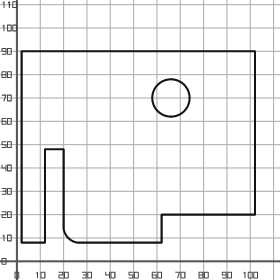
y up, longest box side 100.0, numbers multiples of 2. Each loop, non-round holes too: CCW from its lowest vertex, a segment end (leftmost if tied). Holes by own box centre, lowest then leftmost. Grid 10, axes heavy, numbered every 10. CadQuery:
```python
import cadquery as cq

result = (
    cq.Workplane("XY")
    .moveTo(2.0, 8.0)
    .lineTo(12.0, 8.0)
    .lineTo(12.0, 48.0)
    .lineTo(20.0, 48.0)
    .lineTo(20.0, 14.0)
    .threePointArc((22.0, 10.0), (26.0, 8.0))
    .lineTo(62.0, 8.0)
    .lineTo(62.0, 20.0)
    .lineTo(102.0, 20.0)
    .lineTo(102.0, 90.0)
    .lineTo(2.0, 90.0)
    .close()
    .moveTo(66.0, 70.0)
    .circle(8.0)
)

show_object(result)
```